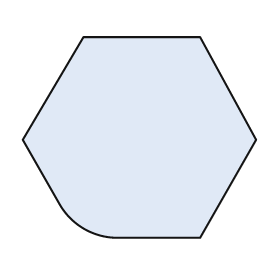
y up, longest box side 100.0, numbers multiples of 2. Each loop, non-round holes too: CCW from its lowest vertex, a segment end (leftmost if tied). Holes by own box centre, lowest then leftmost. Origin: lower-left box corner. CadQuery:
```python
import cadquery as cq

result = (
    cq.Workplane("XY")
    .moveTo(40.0, 0.0)
    .lineTo(76.0, 0.0)
    .lineTo(100.0, 42.0)
    .lineTo(76.0, 86.0)
    .lineTo(26.0, 86.0)
    .lineTo(0.0, 42.0)
    .lineTo(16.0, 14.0)
    .threePointArc((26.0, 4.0), (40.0, 0.0))
    .close()
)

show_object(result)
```